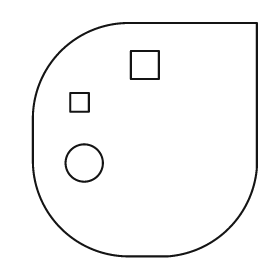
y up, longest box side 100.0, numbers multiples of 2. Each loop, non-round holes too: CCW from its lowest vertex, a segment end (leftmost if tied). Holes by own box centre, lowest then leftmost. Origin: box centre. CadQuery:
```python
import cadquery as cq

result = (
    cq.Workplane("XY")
    .moveTo(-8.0, -50.0)
    .lineTo(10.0, -50.0)
    .threePointArc((36.0, -38.0), (48.0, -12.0))
    .lineTo(48.0, 50.0)
    .lineTo(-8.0, 50.0)
    .threePointArc((-36.0, 38.0), (-48.0, 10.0))
    .lineTo(-48.0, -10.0)
    .threePointArc((-36.0, -38.0), (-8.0, -50.0))
    .close()
    .moveTo(-26.0, -10.0)
    .circle(8.0)
    .moveTo(-32.0, 12.0)
    .lineTo(-24.0, 12.0)
    .lineTo(-24.0, 20.0)
    .lineTo(-32.0, 20.0)
    .close()
    .moveTo(-6.0, 26.0)
    .lineTo(6.0, 26.0)
    .lineTo(6.0, 38.0)
    .lineTo(-6.0, 38.0)
    .close()
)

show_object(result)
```